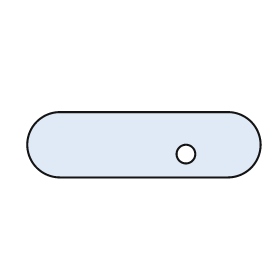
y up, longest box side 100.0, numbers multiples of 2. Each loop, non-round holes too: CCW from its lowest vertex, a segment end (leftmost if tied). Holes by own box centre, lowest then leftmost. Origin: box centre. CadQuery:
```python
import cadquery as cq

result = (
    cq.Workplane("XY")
    .moveTo(-36.0, -14.0)
    .lineTo(36.0, -14.0)
    .threePointArc((50.0, 0.0), (36.0, 14.0))
    .lineTo(-36.0, 14.0)
    .threePointArc((-50.0, 0.0), (-36.0, -14.0))
    .close()
    .moveTo(18.0, -4.0)
    .circle(4.0)
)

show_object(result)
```